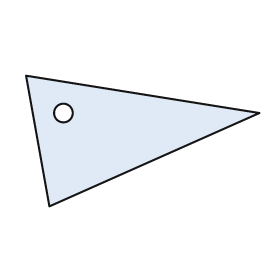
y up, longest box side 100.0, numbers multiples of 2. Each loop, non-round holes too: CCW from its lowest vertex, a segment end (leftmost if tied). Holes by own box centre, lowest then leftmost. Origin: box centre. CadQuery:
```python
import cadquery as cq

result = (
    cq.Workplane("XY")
    .moveTo(-40.0, -28.0)
    .lineTo(50.0, 12.0)
    .lineTo(-50.0, 28.0)
    .close()
    .moveTo(-34.0, 12.0)
    .circle(4.0)
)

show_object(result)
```